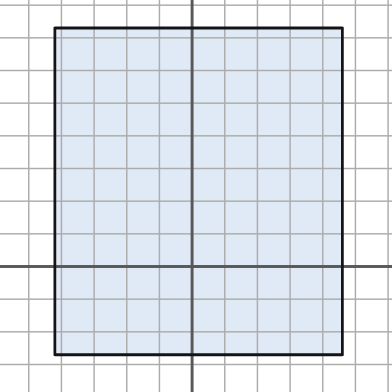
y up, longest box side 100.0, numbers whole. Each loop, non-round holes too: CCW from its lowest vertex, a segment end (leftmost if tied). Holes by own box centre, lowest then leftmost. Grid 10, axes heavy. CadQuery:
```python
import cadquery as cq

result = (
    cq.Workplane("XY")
    .moveTo(-42.0, -27.0)
    .lineTo(46.0, -27.0)
    .lineTo(46.0, 73.0)
    .lineTo(-42.0, 73.0)
    .close()
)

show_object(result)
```